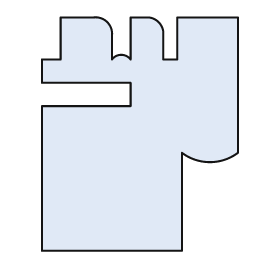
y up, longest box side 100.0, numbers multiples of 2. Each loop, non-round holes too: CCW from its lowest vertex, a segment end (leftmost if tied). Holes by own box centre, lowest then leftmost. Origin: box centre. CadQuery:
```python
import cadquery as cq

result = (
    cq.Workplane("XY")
    .moveTo(-42.0, -50.0)
    .lineTo(18.0, -50.0)
    .lineTo(18.0, -8.0)
    .threePointArc((30.0, -12.0), (42.0, -8.0))
    .lineTo(42.0, 50.0)
    .lineTo(16.0, 50.0)
    .lineTo(16.0, 32.0)
    .lineTo(10.0, 32.0)
    .lineTo(10.0, 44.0)
    .threePointArc((8.0, 48.0), (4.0, 50.0))
    .lineTo(-4.0, 50.0)
    .lineTo(-4.0, 32.0)
    .threePointArc((-8.0, 34.0), (-12.0, 32.0))
    .lineTo(-12.0, 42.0)
    .threePointArc((-14.0, 48.0), (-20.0, 50.0))
    .lineTo(-34.0, 50.0)
    .lineTo(-34.0, 32.0)
    .lineTo(-42.0, 32.0)
    .lineTo(-42.0, 22.0)
    .lineTo(-4.0, 22.0)
    .lineTo(-4.0, 12.0)
    .lineTo(-42.0, 12.0)
    .close()
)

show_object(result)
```